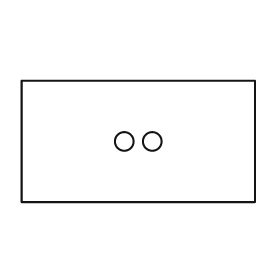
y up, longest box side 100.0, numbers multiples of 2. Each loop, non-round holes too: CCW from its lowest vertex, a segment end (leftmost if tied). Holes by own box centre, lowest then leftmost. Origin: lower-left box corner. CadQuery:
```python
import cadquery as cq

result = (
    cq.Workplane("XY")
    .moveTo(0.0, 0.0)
    .lineTo(100.0, 0.0)
    .lineTo(100.0, 52.0)
    .lineTo(0.0, 52.0)
    .close()
    .moveTo(44.0, 26.0)
    .circle(4.0)
    .moveTo(56.0, 26.0)
    .circle(4.0)
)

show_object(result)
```